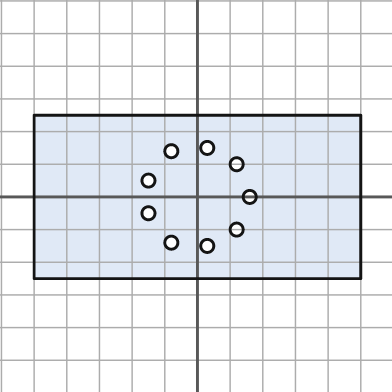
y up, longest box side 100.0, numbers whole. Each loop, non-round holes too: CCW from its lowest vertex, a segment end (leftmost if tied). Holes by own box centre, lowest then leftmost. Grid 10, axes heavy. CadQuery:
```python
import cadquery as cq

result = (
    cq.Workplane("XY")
    .moveTo(-50.0, -25.0)
    .lineTo(50.0, -25.0)
    .lineTo(50.0, 25.0)
    .lineTo(-50.0, 25.0)
    .close()
    .moveTo(3.0, -15.0)
    .circle(2.0)
    .moveTo(-8.0, -14.0)
    .circle(2.0)
    .moveTo(12.0, -10.0)
    .circle(2.0)
    .moveTo(-15.0, -5.0)
    .circle(2.0)
    .moveTo(16.0, 0.0)
    .circle(2.0)
    .moveTo(-15.0, 5.0)
    .circle(2.0)
    .moveTo(12.0, 10.0)
    .circle(2.0)
    .moveTo(-8.0, 14.0)
    .circle(2.0)
    .moveTo(3.0, 15.0)
    .circle(2.0)
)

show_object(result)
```